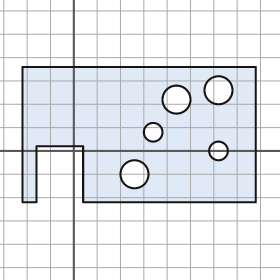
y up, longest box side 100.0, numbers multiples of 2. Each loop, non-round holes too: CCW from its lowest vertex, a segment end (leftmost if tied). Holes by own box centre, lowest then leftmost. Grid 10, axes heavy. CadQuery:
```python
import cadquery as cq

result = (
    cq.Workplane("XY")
    .moveTo(-22.0, -22.0)
    .lineTo(-16.0, -22.0)
    .lineTo(-16.0, 2.0)
    .lineTo(4.0, 2.0)
    .lineTo(4.0, -22.0)
    .lineTo(78.0, -22.0)
    .lineTo(78.0, 36.0)
    .lineTo(-22.0, 36.0)
    .close()
    .moveTo(26.0, -10.0)
    .circle(6.0)
    .moveTo(62.0, 0.0)
    .circle(4.0)
    .moveTo(34.0, 8.0)
    .circle(4.0)
    .moveTo(44.0, 22.0)
    .circle(6.0)
    .moveTo(62.0, 26.0)
    .circle(6.0)
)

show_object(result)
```